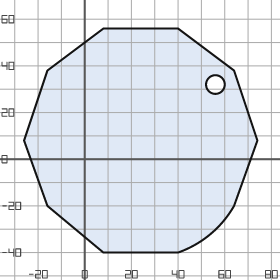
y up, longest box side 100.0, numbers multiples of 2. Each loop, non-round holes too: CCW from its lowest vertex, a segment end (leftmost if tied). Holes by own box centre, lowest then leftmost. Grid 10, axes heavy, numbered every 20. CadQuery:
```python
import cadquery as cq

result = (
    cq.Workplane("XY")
    .moveTo(8.0, -40.0)
    .lineTo(40.0, -40.0)
    .threePointArc((54.0, -32.0), (64.0, -20.0))
    .lineTo(74.0, 8.0)
    .lineTo(64.0, 38.0)
    .lineTo(40.0, 56.0)
    .lineTo(8.0, 56.0)
    .lineTo(-16.0, 38.0)
    .lineTo(-26.0, 8.0)
    .lineTo(-16.0, -20.0)
    .close()
    .moveTo(56.0, 32.0)
    .circle(4.0)
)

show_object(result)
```